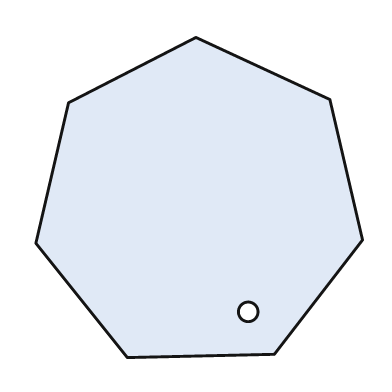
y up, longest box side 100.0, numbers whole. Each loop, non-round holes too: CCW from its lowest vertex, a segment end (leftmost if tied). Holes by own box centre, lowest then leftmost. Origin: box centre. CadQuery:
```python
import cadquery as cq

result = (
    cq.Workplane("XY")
    .moveTo(-22.0, -49.0)
    .lineTo(23.0, -48.0)
    .lineTo(50.0, -13.0)
    .lineTo(40.0, 30.0)
    .lineTo(-1.0, 49.0)
    .lineTo(-40.0, 29.0)
    .lineTo(-50.0, -14.0)
    .close()
    .moveTo(15.0, -35.0)
    .circle(3.0)
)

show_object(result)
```